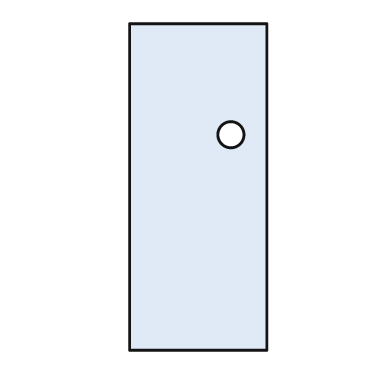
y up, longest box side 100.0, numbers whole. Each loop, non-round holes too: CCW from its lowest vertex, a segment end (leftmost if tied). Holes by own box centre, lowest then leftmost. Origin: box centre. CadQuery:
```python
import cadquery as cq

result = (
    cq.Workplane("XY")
    .moveTo(-21.0, -50.0)
    .lineTo(21.0, -50.0)
    .lineTo(21.0, 50.0)
    .lineTo(-21.0, 50.0)
    .close()
    .moveTo(10.0, 16.0)
    .circle(4.0)
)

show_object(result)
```